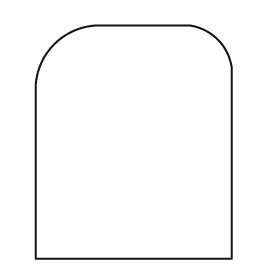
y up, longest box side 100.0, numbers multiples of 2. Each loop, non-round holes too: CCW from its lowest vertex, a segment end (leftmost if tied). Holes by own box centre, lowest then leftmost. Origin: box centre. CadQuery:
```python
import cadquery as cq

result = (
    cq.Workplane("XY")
    .moveTo(-42.0, -50.0)
    .lineTo(42.0, -50.0)
    .lineTo(42.0, 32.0)
    .threePointArc((36.0, 44.0), (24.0, 50.0))
    .lineTo(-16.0, 50.0)
    .threePointArc((-34.0, 42.0), (-42.0, 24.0))
    .close()
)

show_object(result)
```